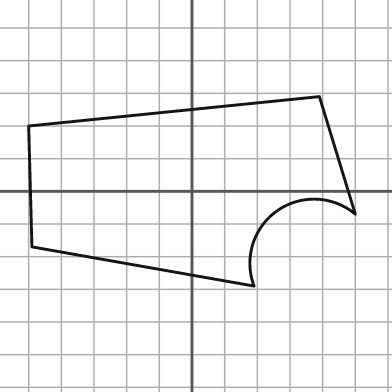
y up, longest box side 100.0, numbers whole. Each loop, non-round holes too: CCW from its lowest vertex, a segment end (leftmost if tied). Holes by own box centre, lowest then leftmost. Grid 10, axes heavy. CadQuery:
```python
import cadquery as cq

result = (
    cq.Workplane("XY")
    .moveTo(19.0, -29.0)
    .threePointArc((26.0, -6.0), (50.0, -7.0))
    .lineTo(39.0, 29.0)
    .lineTo(-50.0, 20.0)
    .lineTo(-49.0, -17.0)
    .close()
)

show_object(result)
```